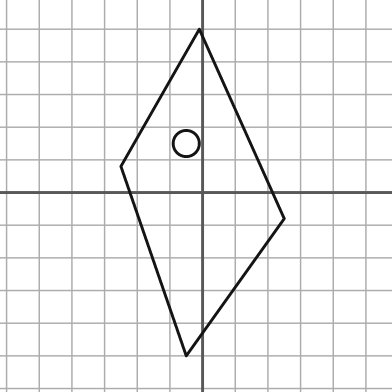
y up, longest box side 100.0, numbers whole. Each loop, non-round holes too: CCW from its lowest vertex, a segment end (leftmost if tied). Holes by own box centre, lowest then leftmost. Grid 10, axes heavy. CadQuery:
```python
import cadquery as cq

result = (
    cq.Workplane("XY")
    .moveTo(-5.0, -50.0)
    .lineTo(25.0, -8.0)
    .lineTo(-1.0, 50.0)
    .lineTo(-25.0, 8.0)
    .close()
    .moveTo(-5.0, 15.0)
    .circle(4.0)
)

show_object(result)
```